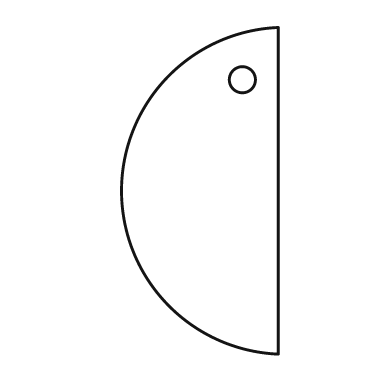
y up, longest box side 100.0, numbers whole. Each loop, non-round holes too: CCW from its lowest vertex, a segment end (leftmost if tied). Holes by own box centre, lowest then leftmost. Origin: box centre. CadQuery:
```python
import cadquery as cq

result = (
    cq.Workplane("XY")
    .moveTo(24.0, -50.0)
    .lineTo(24.0, 50.0)
    .threePointArc((-24.0, 0.0), (24.0, -50.0))
    .close()
    .moveTo(13.0, 34.0)
    .circle(4.0)
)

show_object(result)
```